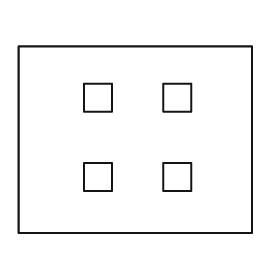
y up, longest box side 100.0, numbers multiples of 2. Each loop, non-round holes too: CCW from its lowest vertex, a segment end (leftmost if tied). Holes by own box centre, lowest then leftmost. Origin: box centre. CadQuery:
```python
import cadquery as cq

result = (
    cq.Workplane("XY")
    .moveTo(-50.0, -40.0)
    .lineTo(50.0, -40.0)
    .lineTo(50.0, 40.0)
    .lineTo(-50.0, 40.0)
    .close()
    .moveTo(-22.0, -22.0)
    .lineTo(-10.0, -22.0)
    .lineTo(-10.0, -10.0)
    .lineTo(-22.0, -10.0)
    .close()
    .moveTo(12.0, -22.0)
    .lineTo(24.0, -22.0)
    .lineTo(24.0, -10.0)
    .lineTo(12.0, -10.0)
    .close()
    .moveTo(-22.0, 12.0)
    .lineTo(-10.0, 12.0)
    .lineTo(-10.0, 24.0)
    .lineTo(-22.0, 24.0)
    .close()
    .moveTo(12.0, 12.0)
    .lineTo(24.0, 12.0)
    .lineTo(24.0, 24.0)
    .lineTo(12.0, 24.0)
    .close()
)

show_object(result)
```